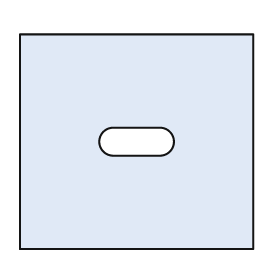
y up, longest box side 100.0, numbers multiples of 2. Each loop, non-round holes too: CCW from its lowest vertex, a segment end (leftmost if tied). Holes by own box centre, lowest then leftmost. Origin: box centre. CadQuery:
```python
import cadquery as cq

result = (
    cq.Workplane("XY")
    .moveTo(-50.0, -46.0)
    .lineTo(50.0, -46.0)
    .lineTo(50.0, 46.0)
    .lineTo(-50.0, 46.0)
    .close()
    .moveTo(-10.0, -6.0)
    .lineTo(10.0, -6.0)
    .threePointArc((16.0, 0.0), (10.0, 6.0))
    .lineTo(-10.0, 6.0)
    .threePointArc((-16.0, 0.0), (-10.0, -6.0))
    .close()
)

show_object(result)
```